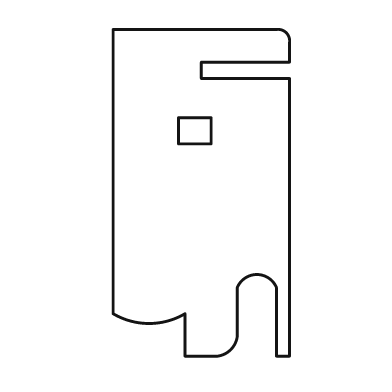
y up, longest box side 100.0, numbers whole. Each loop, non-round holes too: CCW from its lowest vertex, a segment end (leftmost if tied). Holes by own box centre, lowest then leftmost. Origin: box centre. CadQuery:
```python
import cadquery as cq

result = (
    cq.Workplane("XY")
    .moveTo(-5.0, -50.0)
    .lineTo(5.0, -50.0)
    .threePointArc((9.0, -48.0), (11.0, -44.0))
    .lineTo(11.0, -29.0)
    .threePointArc((17.0, -25.0), (23.0, -29.0))
    .lineTo(23.0, -50.0)
    .lineTo(27.0, -50.0)
    .lineTo(27.0, 35.0)
    .lineTo(0.0, 35.0)
    .lineTo(0.0, 40.0)
    .lineTo(27.0, 40.0)
    .lineTo(27.0, 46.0)
    .threePointArc((26.0, 49.0), (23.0, 50.0))
    .lineTo(-27.0, 50.0)
    .lineTo(-27.0, -37.0)
    .threePointArc((-16.0, -40.0), (-5.0, -37.0))
    .close()
    .moveTo(-7.0, 15.0)
    .lineTo(3.0, 15.0)
    .lineTo(3.0, 23.0)
    .lineTo(-7.0, 23.0)
    .close()
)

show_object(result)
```